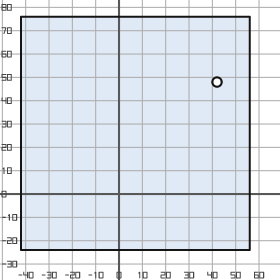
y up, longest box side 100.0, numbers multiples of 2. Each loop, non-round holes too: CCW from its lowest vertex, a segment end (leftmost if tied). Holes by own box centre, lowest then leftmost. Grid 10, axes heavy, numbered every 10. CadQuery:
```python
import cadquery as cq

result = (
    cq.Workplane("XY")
    .moveTo(-42.0, -24.0)
    .lineTo(56.0, -24.0)
    .lineTo(56.0, 76.0)
    .lineTo(-42.0, 76.0)
    .close()
    .moveTo(42.0, 48.0)
    .circle(2.0)
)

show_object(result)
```